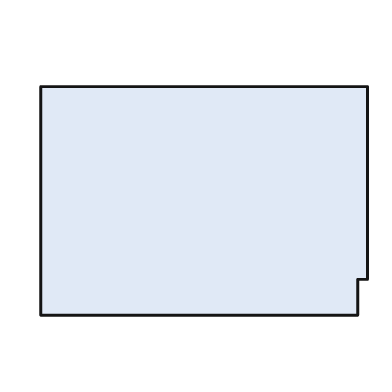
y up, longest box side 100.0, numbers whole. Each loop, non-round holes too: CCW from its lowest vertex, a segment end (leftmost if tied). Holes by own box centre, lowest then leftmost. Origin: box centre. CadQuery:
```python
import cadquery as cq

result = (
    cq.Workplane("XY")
    .moveTo(-50.0, -35.0)
    .lineTo(47.0, -35.0)
    .lineTo(47.0, -24.0)
    .lineTo(50.0, -24.0)
    .lineTo(50.0, 35.0)
    .lineTo(-50.0, 35.0)
    .close()
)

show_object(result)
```